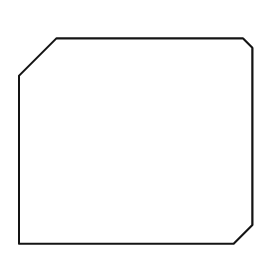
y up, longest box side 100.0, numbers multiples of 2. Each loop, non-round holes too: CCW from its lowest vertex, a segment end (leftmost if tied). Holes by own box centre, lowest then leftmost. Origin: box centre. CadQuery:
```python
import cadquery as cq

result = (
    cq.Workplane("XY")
    .moveTo(-50.0, -44.0)
    .lineTo(42.0, -44.0)
    .lineTo(50.0, -36.0)
    .lineTo(50.0, 40.0)
    .lineTo(46.0, 44.0)
    .lineTo(-34.0, 44.0)
    .lineTo(-50.0, 28.0)
    .close()
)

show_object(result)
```